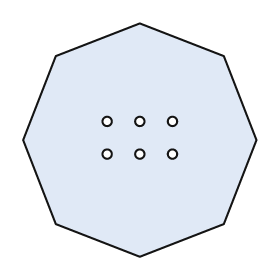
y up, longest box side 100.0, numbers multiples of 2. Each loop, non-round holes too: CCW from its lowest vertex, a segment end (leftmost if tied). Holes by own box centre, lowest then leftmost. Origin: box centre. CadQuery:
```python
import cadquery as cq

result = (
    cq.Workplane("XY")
    .moveTo(0.0, -50.0)
    .lineTo(36.0, -36.0)
    .lineTo(50.0, 0.0)
    .lineTo(36.0, 36.0)
    .lineTo(0.0, 50.0)
    .lineTo(-36.0, 36.0)
    .lineTo(-50.0, 0.0)
    .lineTo(-36.0, -36.0)
    .close()
    .moveTo(-14.0, -6.0)
    .circle(2.0)
    .moveTo(0.0, -6.0)
    .circle(2.0)
    .moveTo(14.0, -6.0)
    .circle(2.0)
    .moveTo(-14.0, 8.0)
    .circle(2.0)
    .moveTo(0.0, 8.0)
    .circle(2.0)
    .moveTo(14.0, 8.0)
    .circle(2.0)
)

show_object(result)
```